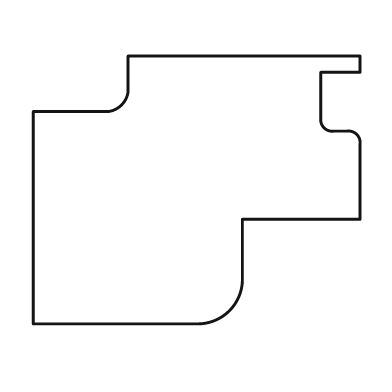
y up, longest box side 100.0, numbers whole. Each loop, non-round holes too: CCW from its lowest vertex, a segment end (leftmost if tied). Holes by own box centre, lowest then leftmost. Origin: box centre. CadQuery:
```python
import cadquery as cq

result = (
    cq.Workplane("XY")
    .moveTo(-50.0, -41.0)
    .lineTo(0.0, -41.0)
    .threePointArc((10.0, -37.0), (14.0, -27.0))
    .lineTo(14.0, -9.0)
    .lineTo(50.0, -9.0)
    .lineTo(50.0, 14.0)
    .threePointArc((49.0, 17.0), (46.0, 18.0))
    .lineTo(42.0, 18.0)
    .threePointArc((39.0, 19.0), (38.0, 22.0))
    .lineTo(38.0, 36.0)
    .lineTo(50.0, 36.0)
    .lineTo(50.0, 41.0)
    .lineTo(-21.0, 41.0)
    .lineTo(-21.0, 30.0)
    .threePointArc((-23.0, 26.0), (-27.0, 24.0))
    .lineTo(-50.0, 24.0)
    .close()
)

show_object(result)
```